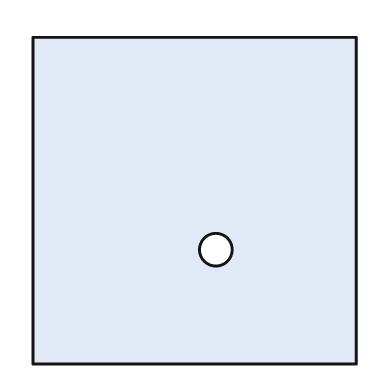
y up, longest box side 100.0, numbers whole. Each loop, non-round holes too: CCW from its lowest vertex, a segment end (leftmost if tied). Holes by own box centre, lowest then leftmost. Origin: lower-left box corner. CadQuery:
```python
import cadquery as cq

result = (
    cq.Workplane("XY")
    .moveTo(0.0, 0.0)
    .lineTo(99.0, 0.0)
    .lineTo(99.0, 100.0)
    .lineTo(0.0, 100.0)
    .close()
    .moveTo(56.0, 35.0)
    .circle(5.0)
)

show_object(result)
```